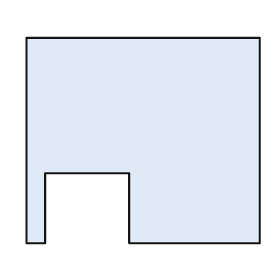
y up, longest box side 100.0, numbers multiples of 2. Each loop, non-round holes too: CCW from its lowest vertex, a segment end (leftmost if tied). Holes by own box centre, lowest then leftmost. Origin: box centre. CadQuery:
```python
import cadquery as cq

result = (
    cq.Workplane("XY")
    .moveTo(-50.0, -44.0)
    .lineTo(-42.0, -44.0)
    .lineTo(-42.0, -14.0)
    .lineTo(-6.0, -14.0)
    .lineTo(-6.0, -44.0)
    .lineTo(50.0, -44.0)
    .lineTo(50.0, 44.0)
    .lineTo(-50.0, 44.0)
    .close()
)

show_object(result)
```